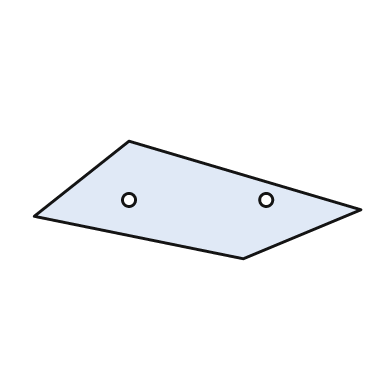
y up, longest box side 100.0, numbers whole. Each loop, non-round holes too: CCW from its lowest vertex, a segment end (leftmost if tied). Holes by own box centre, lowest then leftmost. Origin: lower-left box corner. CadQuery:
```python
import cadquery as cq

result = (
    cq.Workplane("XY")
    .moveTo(64.0, 0.0)
    .lineTo(100.0, 15.0)
    .lineTo(29.0, 36.0)
    .lineTo(0.0, 13.0)
    .close()
    .moveTo(29.0, 18.0)
    .circle(2.0)
    .moveTo(71.0, 18.0)
    .circle(2.0)
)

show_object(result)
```